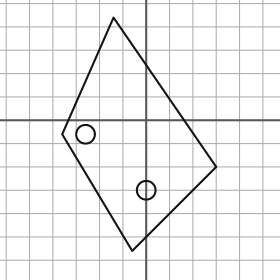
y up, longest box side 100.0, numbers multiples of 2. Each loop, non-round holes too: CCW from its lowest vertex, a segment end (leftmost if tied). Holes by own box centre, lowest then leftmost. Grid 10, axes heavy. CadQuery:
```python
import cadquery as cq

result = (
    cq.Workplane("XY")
    .moveTo(-6.0, -56.0)
    .lineTo(30.0, -20.0)
    .lineTo(-14.0, 44.0)
    .lineTo(-36.0, -6.0)
    .close()
    .moveTo(0.0, -30.0)
    .circle(4.0)
    .moveTo(-26.0, -6.0)
    .circle(4.0)
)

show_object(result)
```